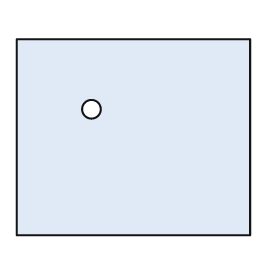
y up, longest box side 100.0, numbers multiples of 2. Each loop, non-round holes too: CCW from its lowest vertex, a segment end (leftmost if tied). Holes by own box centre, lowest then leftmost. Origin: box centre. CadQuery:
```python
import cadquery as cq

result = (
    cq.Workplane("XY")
    .moveTo(-50.0, -42.0)
    .lineTo(50.0, -42.0)
    .lineTo(50.0, 42.0)
    .lineTo(-50.0, 42.0)
    .close()
    .moveTo(-18.0, 12.0)
    .circle(4.0)
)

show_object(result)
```